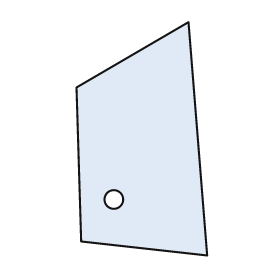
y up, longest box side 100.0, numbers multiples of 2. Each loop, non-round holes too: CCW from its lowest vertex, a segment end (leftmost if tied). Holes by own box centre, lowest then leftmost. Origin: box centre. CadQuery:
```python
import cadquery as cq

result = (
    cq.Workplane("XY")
    .moveTo(28.0, -50.0)
    .lineTo(20.0, 50.0)
    .lineTo(-28.0, 22.0)
    .lineTo(-26.0, -44.0)
    .close()
    .moveTo(-12.0, -26.0)
    .circle(4.0)
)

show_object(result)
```